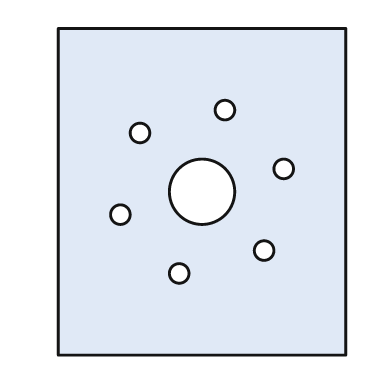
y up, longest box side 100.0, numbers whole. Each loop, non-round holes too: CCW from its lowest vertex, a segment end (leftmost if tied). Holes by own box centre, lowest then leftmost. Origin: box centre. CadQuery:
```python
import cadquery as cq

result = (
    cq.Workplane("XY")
    .moveTo(-44.0, -50.0)
    .lineTo(44.0, -50.0)
    .lineTo(44.0, 50.0)
    .lineTo(-44.0, 50.0)
    .close()
    .moveTo(-7.0, -25.0)
    .circle(3.0)
    .moveTo(19.0, -18.0)
    .circle(3.0)
    .moveTo(-25.0, -7.0)
    .circle(3.0)
    .moveTo(0.0, 0.0)
    .circle(10.0)
    .moveTo(25.0, 7.0)
    .circle(3.0)
    .moveTo(-19.0, 18.0)
    .circle(3.0)
    .moveTo(7.0, 25.0)
    .circle(3.0)
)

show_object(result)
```